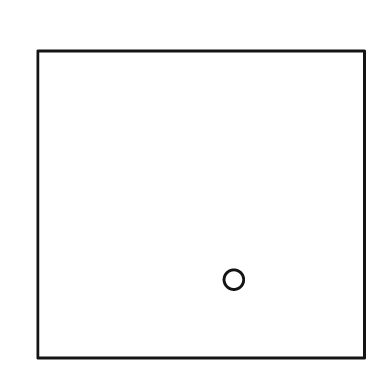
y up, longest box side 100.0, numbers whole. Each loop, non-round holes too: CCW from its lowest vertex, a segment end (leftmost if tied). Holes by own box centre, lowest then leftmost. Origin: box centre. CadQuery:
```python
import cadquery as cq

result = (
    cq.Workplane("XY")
    .moveTo(-50.0, -47.0)
    .lineTo(50.0, -47.0)
    .lineTo(50.0, 47.0)
    .lineTo(-50.0, 47.0)
    .close()
    .moveTo(10.0, -23.0)
    .circle(3.0)
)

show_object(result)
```